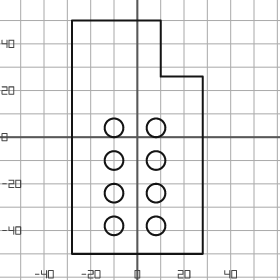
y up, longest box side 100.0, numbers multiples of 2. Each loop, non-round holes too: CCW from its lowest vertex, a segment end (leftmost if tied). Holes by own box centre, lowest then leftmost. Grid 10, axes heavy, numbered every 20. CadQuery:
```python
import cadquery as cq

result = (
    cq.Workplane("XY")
    .moveTo(-28.0, -50.0)
    .lineTo(28.0, -50.0)
    .lineTo(28.0, 26.0)
    .lineTo(10.0, 26.0)
    .lineTo(10.0, 50.0)
    .lineTo(-28.0, 50.0)
    .close()
    .moveTo(-10.0, -38.0)
    .circle(4.0)
    .moveTo(8.0, -38.0)
    .circle(4.0)
    .moveTo(-10.0, -24.0)
    .circle(4.0)
    .moveTo(8.0, -24.0)
    .circle(4.0)
    .moveTo(-10.0, -10.0)
    .circle(4.0)
    .moveTo(8.0, -10.0)
    .circle(4.0)
    .moveTo(-10.0, 4.0)
    .circle(4.0)
    .moveTo(8.0, 4.0)
    .circle(4.0)
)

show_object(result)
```